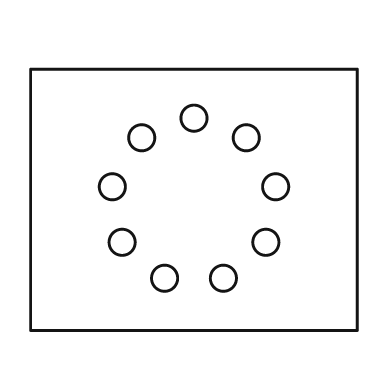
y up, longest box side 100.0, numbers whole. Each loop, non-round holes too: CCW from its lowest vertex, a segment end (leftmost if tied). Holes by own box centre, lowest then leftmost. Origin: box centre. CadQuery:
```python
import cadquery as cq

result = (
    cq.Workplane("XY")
    .moveTo(-50.0, -40.0)
    .lineTo(50.0, -40.0)
    .lineTo(50.0, 40.0)
    .lineTo(-50.0, 40.0)
    .close()
    .moveTo(-9.0, -24.0)
    .circle(4.0)
    .moveTo(9.0, -24.0)
    .circle(4.0)
    .moveTo(-22.0, -13.0)
    .circle(4.0)
    .moveTo(22.0, -13.0)
    .circle(4.0)
    .moveTo(-25.0, 4.0)
    .circle(4.0)
    .moveTo(25.0, 4.0)
    .circle(4.0)
    .moveTo(-16.0, 19.0)
    .circle(4.0)
    .moveTo(16.0, 19.0)
    .circle(4.0)
    .moveTo(0.0, 25.0)
    .circle(4.0)
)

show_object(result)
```